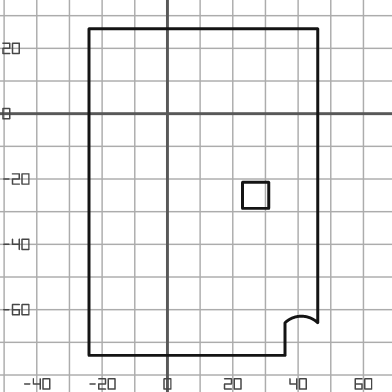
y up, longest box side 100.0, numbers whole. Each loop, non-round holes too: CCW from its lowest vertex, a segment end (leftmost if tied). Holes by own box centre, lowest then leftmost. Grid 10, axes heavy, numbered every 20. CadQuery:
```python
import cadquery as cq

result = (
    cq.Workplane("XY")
    .moveTo(-24.0, -74.0)
    .lineTo(36.0, -74.0)
    .lineTo(36.0, -64.0)
    .threePointArc((41.0, -62.0), (46.0, -64.0))
    .lineTo(46.0, 26.0)
    .lineTo(-24.0, 26.0)
    .close()
    .moveTo(23.0, -29.0)
    .lineTo(31.0, -29.0)
    .lineTo(31.0, -21.0)
    .lineTo(23.0, -21.0)
    .close()
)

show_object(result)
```